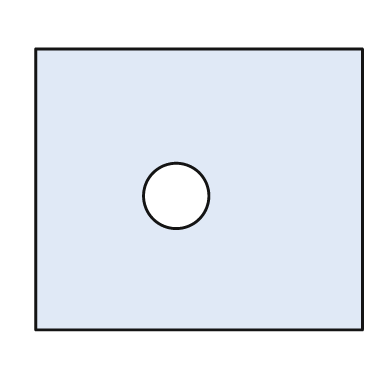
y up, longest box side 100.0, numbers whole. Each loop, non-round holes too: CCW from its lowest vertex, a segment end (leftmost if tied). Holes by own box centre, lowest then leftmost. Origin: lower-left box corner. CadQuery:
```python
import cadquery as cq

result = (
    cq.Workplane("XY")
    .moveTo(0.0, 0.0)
    .lineTo(100.0, 0.0)
    .lineTo(100.0, 86.0)
    .lineTo(0.0, 86.0)
    .close()
    .moveTo(43.0, 41.0)
    .circle(10.0)
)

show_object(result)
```